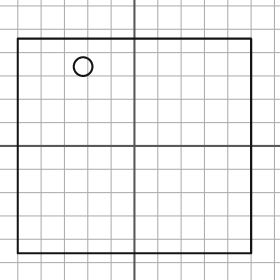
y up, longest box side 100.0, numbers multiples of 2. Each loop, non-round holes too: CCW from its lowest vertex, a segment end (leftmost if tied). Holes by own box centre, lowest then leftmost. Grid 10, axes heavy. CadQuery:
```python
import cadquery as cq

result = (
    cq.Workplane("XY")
    .moveTo(-50.0, -46.0)
    .lineTo(50.0, -46.0)
    .lineTo(50.0, 46.0)
    .lineTo(-50.0, 46.0)
    .close()
    .moveTo(-22.0, 34.0)
    .circle(4.0)
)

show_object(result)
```